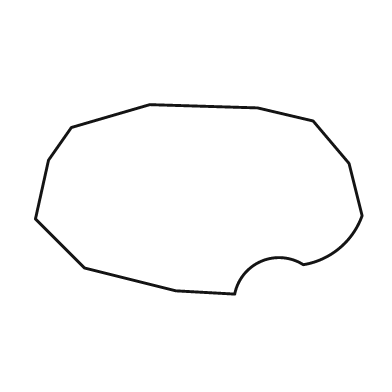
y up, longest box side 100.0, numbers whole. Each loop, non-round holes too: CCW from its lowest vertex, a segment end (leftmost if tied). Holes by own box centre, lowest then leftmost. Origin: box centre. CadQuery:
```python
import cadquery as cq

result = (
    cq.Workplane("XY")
    .moveTo(11.0, -29.0)
    .threePointArc((19.0, -19.0), (32.0, -20.0))
    .threePointArc((43.0, -15.0), (50.0, -5.0))
    .lineTo(46.0, 11.0)
    .lineTo(35.0, 24.0)
    .lineTo(18.0, 28.0)
    .lineTo(-15.0, 29.0)
    .lineTo(-39.0, 22.0)
    .lineTo(-46.0, 12.0)
    .lineTo(-50.0, -6.0)
    .lineTo(-35.0, -21.0)
    .lineTo(-7.0, -28.0)
    .close()
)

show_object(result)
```